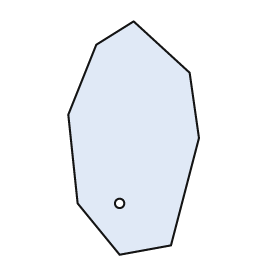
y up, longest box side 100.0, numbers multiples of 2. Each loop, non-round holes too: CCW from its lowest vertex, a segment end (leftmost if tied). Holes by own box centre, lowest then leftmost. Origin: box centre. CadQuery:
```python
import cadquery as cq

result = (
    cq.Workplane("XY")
    .moveTo(-6.0, -50.0)
    .lineTo(16.0, -46.0)
    .lineTo(28.0, 0.0)
    .lineTo(24.0, 28.0)
    .lineTo(0.0, 50.0)
    .lineTo(-16.0, 40.0)
    .lineTo(-28.0, 10.0)
    .lineTo(-24.0, -28.0)
    .close()
    .moveTo(-6.0, -28.0)
    .circle(2.0)
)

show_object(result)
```